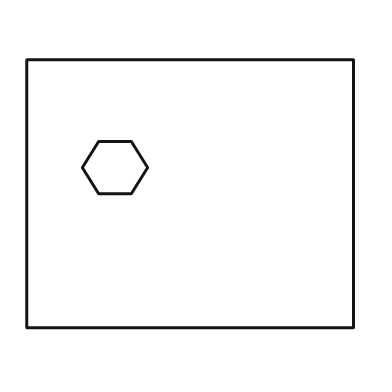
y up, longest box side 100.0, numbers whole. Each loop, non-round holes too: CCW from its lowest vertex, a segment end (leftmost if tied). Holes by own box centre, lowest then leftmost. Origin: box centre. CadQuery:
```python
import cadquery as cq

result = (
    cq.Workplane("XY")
    .moveTo(-50.0, -41.0)
    .lineTo(50.0, -41.0)
    .lineTo(50.0, 41.0)
    .lineTo(-50.0, 41.0)
    .close()
    .moveTo(-28.0, 0.0)
    .lineTo(-18.0, 0.0)
    .lineTo(-13.0, 8.0)
    .lineTo(-18.0, 16.0)
    .lineTo(-28.0, 16.0)
    .lineTo(-33.0, 8.0)
    .close()
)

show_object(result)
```